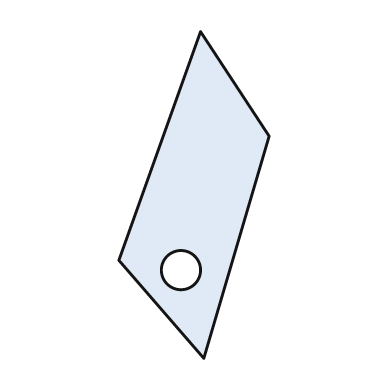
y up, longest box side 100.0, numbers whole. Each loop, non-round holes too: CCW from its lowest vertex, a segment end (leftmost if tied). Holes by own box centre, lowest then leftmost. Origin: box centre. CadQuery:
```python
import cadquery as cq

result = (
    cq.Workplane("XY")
    .moveTo(3.0, -50.0)
    .lineTo(23.0, 18.0)
    .lineTo(2.0, 50.0)
    .lineTo(-23.0, -20.0)
    .close()
    .moveTo(-4.0, -23.0)
    .circle(6.0)
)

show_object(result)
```